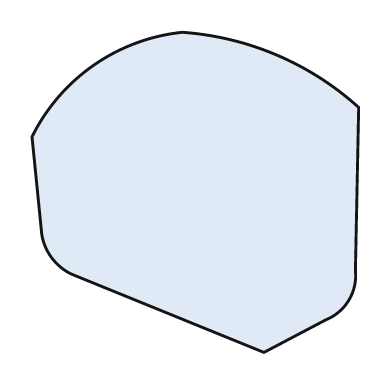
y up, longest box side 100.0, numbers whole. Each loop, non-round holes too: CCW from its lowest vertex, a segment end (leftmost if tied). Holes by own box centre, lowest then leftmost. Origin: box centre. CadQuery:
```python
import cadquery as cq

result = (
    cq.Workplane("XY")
    .moveTo(21.0, -49.0)
    .lineTo(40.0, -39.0)
    .threePointArc((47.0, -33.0), (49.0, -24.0))
    .lineTo(50.0, 26.0)
    .threePointArc((25.0, 42.0), (-4.0, 49.0))
    .threePointArc((-31.0, 39.0), (-50.0, 17.0))
    .lineTo(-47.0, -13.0)
    .threePointArc((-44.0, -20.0), (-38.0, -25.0))
    .close()
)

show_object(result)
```